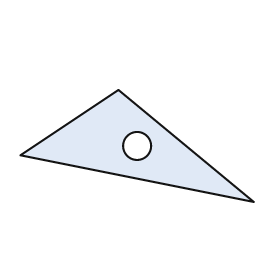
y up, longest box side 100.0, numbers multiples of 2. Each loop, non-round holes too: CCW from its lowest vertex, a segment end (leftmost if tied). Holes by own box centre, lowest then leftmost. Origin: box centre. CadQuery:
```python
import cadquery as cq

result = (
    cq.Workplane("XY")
    .moveTo(50.0, -24.0)
    .lineTo(-8.0, 24.0)
    .lineTo(-50.0, -4.0)
    .close()
    .moveTo(0.0, 0.0)
    .circle(6.0)
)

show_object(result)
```